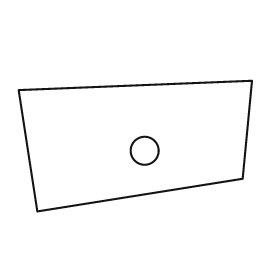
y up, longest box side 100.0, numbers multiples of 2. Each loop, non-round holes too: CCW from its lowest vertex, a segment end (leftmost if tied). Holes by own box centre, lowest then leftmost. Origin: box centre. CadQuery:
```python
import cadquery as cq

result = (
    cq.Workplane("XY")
    .moveTo(-42.0, -28.0)
    .lineTo(46.0, -14.0)
    .lineTo(50.0, 28.0)
    .lineTo(-50.0, 24.0)
    .close()
    .moveTo(4.0, -2.0)
    .circle(6.0)
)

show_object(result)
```